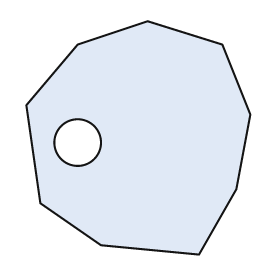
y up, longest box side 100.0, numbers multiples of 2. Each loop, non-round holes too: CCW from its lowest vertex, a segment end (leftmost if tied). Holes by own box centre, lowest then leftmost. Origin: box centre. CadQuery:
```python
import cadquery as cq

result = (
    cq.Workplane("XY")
    .moveTo(26.0, -50.0)
    .lineTo(42.0, -22.0)
    .lineTo(48.0, 10.0)
    .lineTo(36.0, 40.0)
    .lineTo(4.0, 50.0)
    .lineTo(-26.0, 40.0)
    .lineTo(-48.0, 14.0)
    .lineTo(-42.0, -28.0)
    .lineTo(-16.0, -46.0)
    .close()
    .moveTo(-26.0, -2.0)
    .circle(10.0)
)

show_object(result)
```